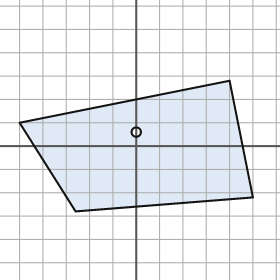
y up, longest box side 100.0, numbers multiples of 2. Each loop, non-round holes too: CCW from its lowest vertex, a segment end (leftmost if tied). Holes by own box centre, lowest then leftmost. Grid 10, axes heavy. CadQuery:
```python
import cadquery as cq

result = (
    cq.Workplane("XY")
    .moveTo(-26.0, -28.0)
    .lineTo(50.0, -22.0)
    .lineTo(40.0, 28.0)
    .lineTo(-50.0, 10.0)
    .close()
    .moveTo(0.0, 6.0)
    .circle(2.0)
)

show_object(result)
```